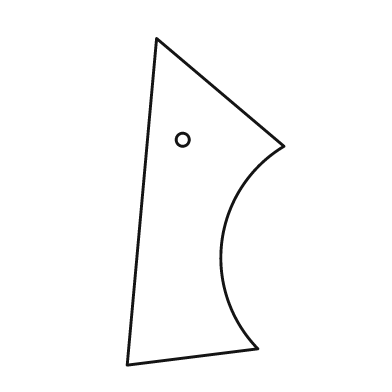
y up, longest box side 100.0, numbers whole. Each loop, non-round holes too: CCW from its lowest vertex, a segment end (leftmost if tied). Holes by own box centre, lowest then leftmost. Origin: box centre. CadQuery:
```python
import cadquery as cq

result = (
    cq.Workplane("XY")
    .moveTo(-24.0, -50.0)
    .lineTo(16.0, -45.0)
    .threePointArc((5.0, -12.0), (24.0, 17.0))
    .lineTo(-15.0, 50.0)
    .close()
    .moveTo(-7.0, 19.0)
    .circle(2.0)
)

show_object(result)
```